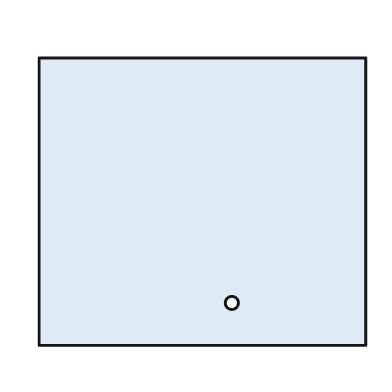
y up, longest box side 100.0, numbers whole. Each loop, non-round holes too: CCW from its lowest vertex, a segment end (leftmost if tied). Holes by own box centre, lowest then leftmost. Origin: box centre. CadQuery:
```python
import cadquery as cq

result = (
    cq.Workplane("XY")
    .moveTo(-50.0, -44.0)
    .lineTo(50.0, -44.0)
    .lineTo(50.0, 44.0)
    .lineTo(-50.0, 44.0)
    .close()
    .moveTo(9.0, -31.0)
    .circle(2.0)
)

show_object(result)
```